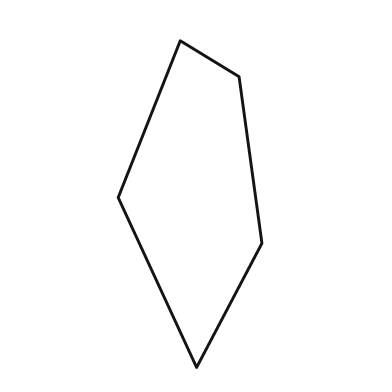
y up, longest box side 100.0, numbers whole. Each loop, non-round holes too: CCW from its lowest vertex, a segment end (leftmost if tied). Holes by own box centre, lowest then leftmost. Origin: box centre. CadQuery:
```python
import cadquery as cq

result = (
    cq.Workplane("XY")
    .moveTo(2.0, -50.0)
    .lineTo(22.0, -12.0)
    .lineTo(15.0, 39.0)
    .lineTo(-3.0, 50.0)
    .lineTo(-22.0, 2.0)
    .close()
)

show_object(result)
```